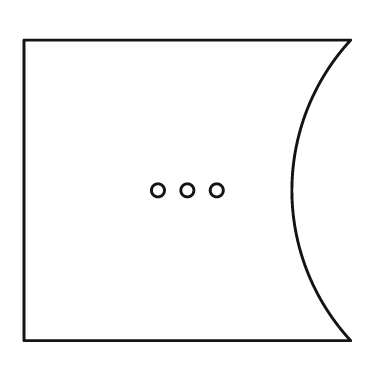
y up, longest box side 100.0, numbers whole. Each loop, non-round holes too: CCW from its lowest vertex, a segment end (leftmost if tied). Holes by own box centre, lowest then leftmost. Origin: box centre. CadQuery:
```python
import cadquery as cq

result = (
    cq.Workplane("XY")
    .moveTo(-50.0, -46.0)
    .lineTo(50.0, -46.0)
    .threePointArc((32.0, 0.0), (50.0, 46.0))
    .lineTo(-50.0, 46.0)
    .close()
    .moveTo(-9.0, 0.0)
    .circle(2.0)
    .moveTo(0.0, 0.0)
    .circle(2.0)
    .moveTo(9.0, 0.0)
    .circle(2.0)
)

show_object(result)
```